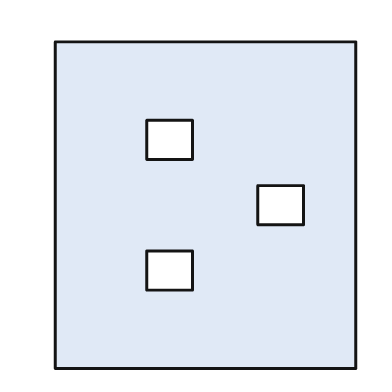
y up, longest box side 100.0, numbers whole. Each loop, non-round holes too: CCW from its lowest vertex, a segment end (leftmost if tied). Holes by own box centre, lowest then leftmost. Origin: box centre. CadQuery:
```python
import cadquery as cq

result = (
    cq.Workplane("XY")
    .moveTo(-46.0, -50.0)
    .lineTo(46.0, -50.0)
    .lineTo(46.0, 50.0)
    .lineTo(-46.0, 50.0)
    .close()
    .moveTo(-18.0, -26.0)
    .lineTo(-4.0, -26.0)
    .lineTo(-4.0, -14.0)
    .lineTo(-18.0, -14.0)
    .close()
    .moveTo(16.0, -6.0)
    .lineTo(30.0, -6.0)
    .lineTo(30.0, 6.0)
    .lineTo(16.0, 6.0)
    .close()
    .moveTo(-18.0, 14.0)
    .lineTo(-4.0, 14.0)
    .lineTo(-4.0, 26.0)
    .lineTo(-18.0, 26.0)
    .close()
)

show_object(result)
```